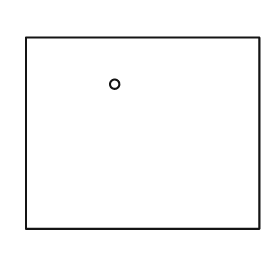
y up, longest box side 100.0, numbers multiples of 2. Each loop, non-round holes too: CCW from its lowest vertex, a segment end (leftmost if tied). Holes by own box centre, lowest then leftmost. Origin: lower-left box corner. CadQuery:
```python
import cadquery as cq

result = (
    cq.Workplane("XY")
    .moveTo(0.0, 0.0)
    .lineTo(100.0, 0.0)
    .lineTo(100.0, 82.0)
    .lineTo(0.0, 82.0)
    .close()
    .moveTo(38.0, 62.0)
    .circle(2.0)
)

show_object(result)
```